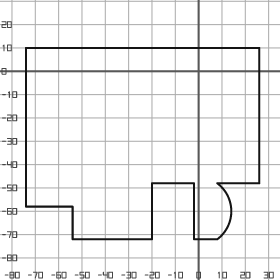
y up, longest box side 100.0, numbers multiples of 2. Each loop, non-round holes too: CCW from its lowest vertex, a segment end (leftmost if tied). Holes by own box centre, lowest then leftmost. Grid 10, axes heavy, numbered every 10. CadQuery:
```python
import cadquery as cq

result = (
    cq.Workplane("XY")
    .moveTo(-54.0, -72.0)
    .lineTo(-20.0, -72.0)
    .lineTo(-20.0, -48.0)
    .lineTo(-2.0, -48.0)
    .lineTo(-2.0, -72.0)
    .lineTo(8.0, -72.0)
    .threePointArc((14.0, -60.0), (8.0, -48.0))
    .lineTo(26.0, -48.0)
    .lineTo(26.0, 10.0)
    .lineTo(-74.0, 10.0)
    .lineTo(-74.0, -58.0)
    .lineTo(-54.0, -58.0)
    .close()
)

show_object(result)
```